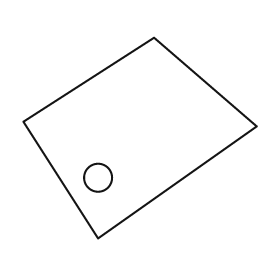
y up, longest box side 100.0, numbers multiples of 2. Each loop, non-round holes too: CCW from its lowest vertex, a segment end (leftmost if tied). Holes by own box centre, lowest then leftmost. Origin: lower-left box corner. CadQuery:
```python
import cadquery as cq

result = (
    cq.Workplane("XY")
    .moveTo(32.0, 0.0)
    .lineTo(100.0, 48.0)
    .lineTo(56.0, 86.0)
    .lineTo(0.0, 50.0)
    .close()
    .moveTo(32.0, 26.0)
    .circle(6.0)
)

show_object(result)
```